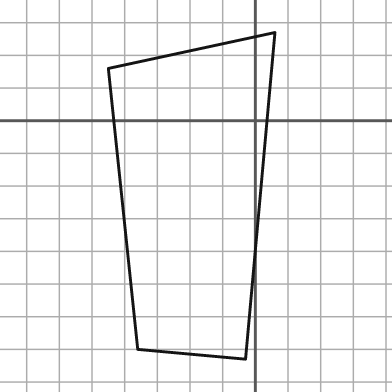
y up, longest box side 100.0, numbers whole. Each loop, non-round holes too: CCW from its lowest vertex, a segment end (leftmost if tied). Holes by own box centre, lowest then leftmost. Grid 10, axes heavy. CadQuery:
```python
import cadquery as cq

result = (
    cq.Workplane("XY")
    .moveTo(-3.0, -73.0)
    .lineTo(6.0, 27.0)
    .lineTo(-45.0, 16.0)
    .lineTo(-36.0, -70.0)
    .close()
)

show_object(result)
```